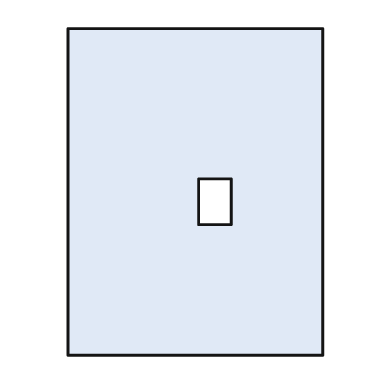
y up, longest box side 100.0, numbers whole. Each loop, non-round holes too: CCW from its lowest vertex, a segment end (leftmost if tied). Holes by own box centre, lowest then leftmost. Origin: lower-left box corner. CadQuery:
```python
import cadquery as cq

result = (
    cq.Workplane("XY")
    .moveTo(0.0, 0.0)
    .lineTo(78.0, 0.0)
    .lineTo(78.0, 100.0)
    .lineTo(0.0, 100.0)
    .close()
    .moveTo(40.0, 40.0)
    .lineTo(50.0, 40.0)
    .lineTo(50.0, 54.0)
    .lineTo(40.0, 54.0)
    .close()
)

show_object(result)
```